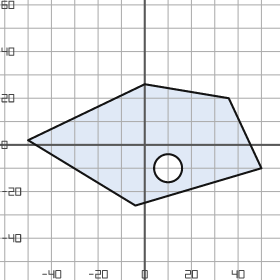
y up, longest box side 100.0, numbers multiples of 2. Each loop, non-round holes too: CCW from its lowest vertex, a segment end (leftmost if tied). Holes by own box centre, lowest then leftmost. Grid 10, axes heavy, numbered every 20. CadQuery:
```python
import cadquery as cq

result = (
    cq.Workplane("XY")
    .moveTo(-4.0, -26.0)
    .lineTo(50.0, -10.0)
    .lineTo(36.0, 20.0)
    .lineTo(0.0, 26.0)
    .lineTo(-50.0, 2.0)
    .close()
    .moveTo(10.0, -10.0)
    .circle(6.0)
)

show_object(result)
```